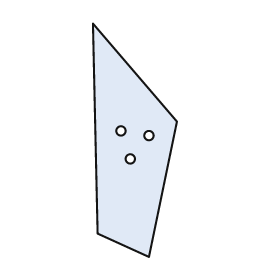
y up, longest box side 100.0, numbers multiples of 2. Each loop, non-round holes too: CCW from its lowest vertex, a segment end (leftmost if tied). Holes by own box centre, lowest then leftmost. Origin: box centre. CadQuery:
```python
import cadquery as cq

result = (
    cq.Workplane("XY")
    .moveTo(6.0, -50.0)
    .lineTo(18.0, 8.0)
    .lineTo(-18.0, 50.0)
    .lineTo(-16.0, -40.0)
    .close()
    .moveTo(-2.0, -8.0)
    .circle(2.0)
    .moveTo(6.0, 2.0)
    .circle(2.0)
    .moveTo(-6.0, 4.0)
    .circle(2.0)
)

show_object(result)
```